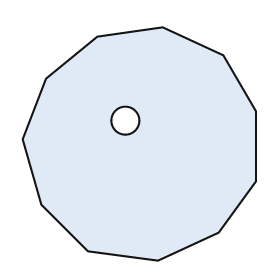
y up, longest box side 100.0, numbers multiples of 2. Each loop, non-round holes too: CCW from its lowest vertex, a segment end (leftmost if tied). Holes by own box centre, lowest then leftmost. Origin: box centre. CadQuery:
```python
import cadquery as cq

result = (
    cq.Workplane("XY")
    .moveTo(8.0, -50.0)
    .lineTo(34.0, -38.0)
    .lineTo(50.0, -16.0)
    .lineTo(50.0, 14.0)
    .lineTo(36.0, 38.0)
    .lineTo(10.0, 50.0)
    .lineTo(-18.0, 46.0)
    .lineTo(-40.0, 28.0)
    .lineTo(-50.0, 2.0)
    .lineTo(-42.0, -26.0)
    .lineTo(-22.0, -46.0)
    .close()
    .moveTo(-6.0, 10.0)
    .circle(6.0)
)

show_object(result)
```